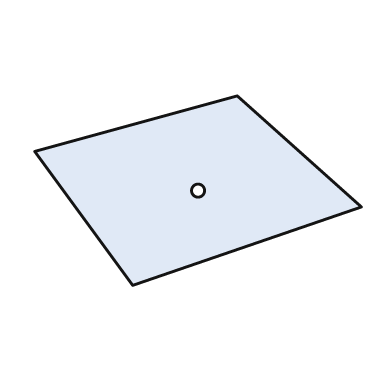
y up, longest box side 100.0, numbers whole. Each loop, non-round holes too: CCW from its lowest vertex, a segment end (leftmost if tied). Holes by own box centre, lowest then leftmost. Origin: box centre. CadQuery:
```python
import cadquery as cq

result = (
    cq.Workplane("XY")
    .moveTo(-20.0, -29.0)
    .lineTo(50.0, -5.0)
    .lineTo(12.0, 29.0)
    .lineTo(-50.0, 12.0)
    .close()
    .moveTo(0.0, 0.0)
    .circle(2.0)
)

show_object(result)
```